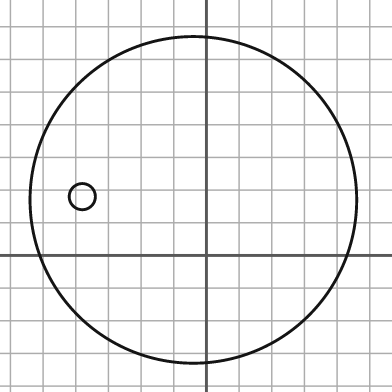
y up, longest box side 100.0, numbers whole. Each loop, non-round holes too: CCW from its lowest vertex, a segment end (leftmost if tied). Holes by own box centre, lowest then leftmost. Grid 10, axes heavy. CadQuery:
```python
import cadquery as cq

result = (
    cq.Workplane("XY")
    .moveTo(-4.0, 17.0)
    .circle(50.0)
    .moveTo(-38.0, 18.0)
    .circle(4.0)
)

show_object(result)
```